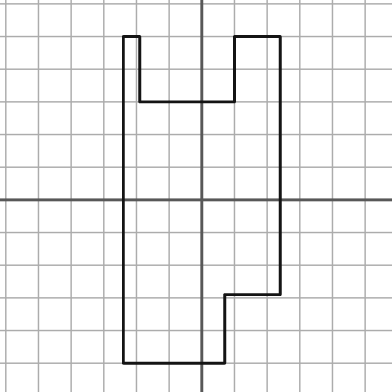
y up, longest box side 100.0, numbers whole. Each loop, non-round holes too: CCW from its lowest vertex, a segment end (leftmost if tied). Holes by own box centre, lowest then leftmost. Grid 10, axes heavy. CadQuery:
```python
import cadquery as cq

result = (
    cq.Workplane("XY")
    .moveTo(-24.0, -50.0)
    .lineTo(7.0, -50.0)
    .lineTo(7.0, -29.0)
    .lineTo(24.0, -29.0)
    .lineTo(24.0, 50.0)
    .lineTo(10.0, 50.0)
    .lineTo(10.0, 30.0)
    .lineTo(-19.0, 30.0)
    .lineTo(-19.0, 50.0)
    .lineTo(-24.0, 50.0)
    .close()
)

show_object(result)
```